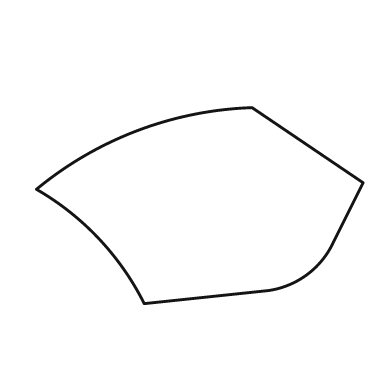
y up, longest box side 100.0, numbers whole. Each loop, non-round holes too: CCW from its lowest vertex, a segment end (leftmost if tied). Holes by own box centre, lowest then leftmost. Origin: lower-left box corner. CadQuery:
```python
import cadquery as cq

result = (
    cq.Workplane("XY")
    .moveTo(33.0, 0.0)
    .lineTo(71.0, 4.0)
    .threePointArc((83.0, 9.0), (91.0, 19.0))
    .lineTo(100.0, 37.0)
    .lineTo(66.0, 60.0)
    .threePointArc((31.0, 53.0), (0.0, 35.0))
    .threePointArc((19.0, 20.0), (33.0, 0.0))
    .close()
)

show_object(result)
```